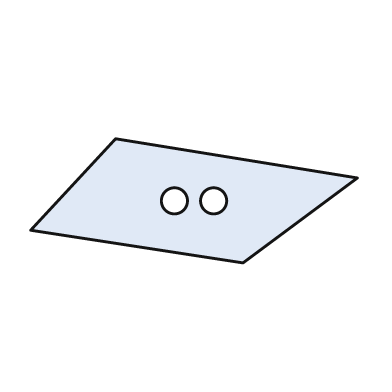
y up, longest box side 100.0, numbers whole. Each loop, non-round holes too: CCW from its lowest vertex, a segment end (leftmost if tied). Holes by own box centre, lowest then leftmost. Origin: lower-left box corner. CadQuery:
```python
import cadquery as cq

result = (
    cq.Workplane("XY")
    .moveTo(65.0, 0.0)
    .lineTo(100.0, 26.0)
    .lineTo(26.0, 38.0)
    .lineTo(0.0, 10.0)
    .close()
    .moveTo(44.0, 19.0)
    .circle(4.0)
    .moveTo(56.0, 19.0)
    .circle(4.0)
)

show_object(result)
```